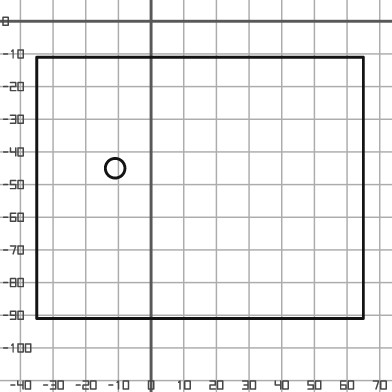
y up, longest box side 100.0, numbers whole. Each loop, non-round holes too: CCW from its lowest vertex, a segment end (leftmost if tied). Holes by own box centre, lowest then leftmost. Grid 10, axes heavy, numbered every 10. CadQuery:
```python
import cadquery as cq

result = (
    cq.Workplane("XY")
    .moveTo(-35.0, -91.0)
    .lineTo(65.0, -91.0)
    .lineTo(65.0, -11.0)
    .lineTo(-35.0, -11.0)
    .close()
    .moveTo(-11.0, -45.0)
    .circle(3.0)
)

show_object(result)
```